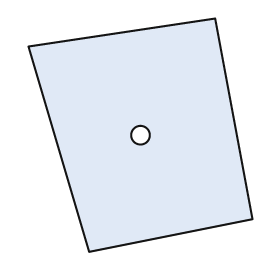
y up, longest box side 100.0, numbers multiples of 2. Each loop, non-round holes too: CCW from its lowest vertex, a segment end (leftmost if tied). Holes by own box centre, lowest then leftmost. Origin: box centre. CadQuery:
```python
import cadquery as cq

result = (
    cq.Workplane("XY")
    .moveTo(-22.0, -50.0)
    .lineTo(48.0, -36.0)
    .lineTo(32.0, 50.0)
    .lineTo(-48.0, 38.0)
    .close()
    .moveTo(0.0, 0.0)
    .circle(4.0)
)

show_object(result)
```